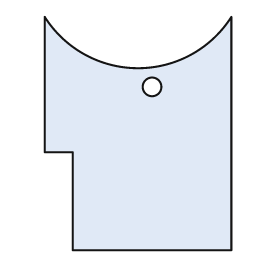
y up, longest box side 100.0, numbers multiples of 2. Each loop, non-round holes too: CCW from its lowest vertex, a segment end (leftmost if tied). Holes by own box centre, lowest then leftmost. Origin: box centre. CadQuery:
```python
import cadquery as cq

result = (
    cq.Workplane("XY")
    .moveTo(-28.0, -50.0)
    .lineTo(40.0, -50.0)
    .lineTo(40.0, 50.0)
    .threePointArc((0.0, 28.0), (-40.0, 50.0))
    .lineTo(-40.0, -8.0)
    .lineTo(-28.0, -8.0)
    .close()
    .moveTo(6.0, 20.0)
    .circle(4.0)
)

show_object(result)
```